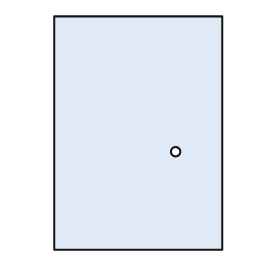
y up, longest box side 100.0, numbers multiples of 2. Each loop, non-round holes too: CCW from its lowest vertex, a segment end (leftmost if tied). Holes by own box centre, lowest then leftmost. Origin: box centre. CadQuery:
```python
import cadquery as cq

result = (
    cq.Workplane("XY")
    .moveTo(-36.0, -50.0)
    .lineTo(36.0, -50.0)
    .lineTo(36.0, 50.0)
    .lineTo(-36.0, 50.0)
    .close()
    .moveTo(16.0, -8.0)
    .circle(2.0)
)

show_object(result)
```